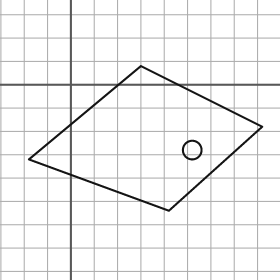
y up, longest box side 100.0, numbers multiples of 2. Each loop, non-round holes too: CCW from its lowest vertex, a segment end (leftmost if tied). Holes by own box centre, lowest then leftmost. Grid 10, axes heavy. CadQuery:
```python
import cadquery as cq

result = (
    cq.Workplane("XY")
    .moveTo(42.0, -54.0)
    .lineTo(82.0, -18.0)
    .lineTo(30.0, 8.0)
    .lineTo(-18.0, -32.0)
    .close()
    .moveTo(52.0, -28.0)
    .circle(4.0)
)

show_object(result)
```